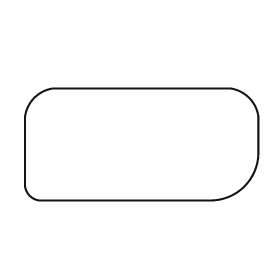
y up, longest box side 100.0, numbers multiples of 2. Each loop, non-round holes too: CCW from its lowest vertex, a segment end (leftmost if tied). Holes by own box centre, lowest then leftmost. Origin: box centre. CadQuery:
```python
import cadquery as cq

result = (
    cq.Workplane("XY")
    .moveTo(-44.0, -24.0)
    .lineTo(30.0, -24.0)
    .threePointArc((44.0, -18.0), (50.0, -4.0))
    .lineTo(50.0, 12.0)
    .threePointArc((46.0, 20.0), (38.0, 24.0))
    .lineTo(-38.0, 24.0)
    .threePointArc((-46.0, 20.0), (-50.0, 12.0))
    .lineTo(-50.0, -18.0)
    .threePointArc((-48.0, -22.0), (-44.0, -24.0))
    .close()
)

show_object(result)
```